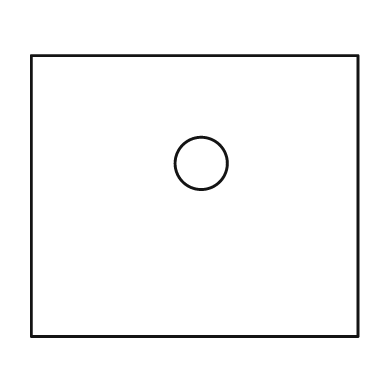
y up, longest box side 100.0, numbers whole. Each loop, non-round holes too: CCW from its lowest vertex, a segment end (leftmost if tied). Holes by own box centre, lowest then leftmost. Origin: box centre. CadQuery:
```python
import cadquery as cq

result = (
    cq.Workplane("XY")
    .moveTo(-50.0, -43.0)
    .lineTo(50.0, -43.0)
    .lineTo(50.0, 43.0)
    .lineTo(-50.0, 43.0)
    .close()
    .moveTo(2.0, 10.0)
    .circle(8.0)
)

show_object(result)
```